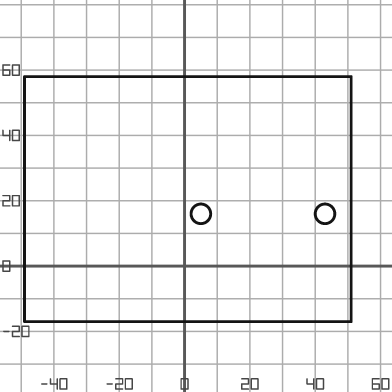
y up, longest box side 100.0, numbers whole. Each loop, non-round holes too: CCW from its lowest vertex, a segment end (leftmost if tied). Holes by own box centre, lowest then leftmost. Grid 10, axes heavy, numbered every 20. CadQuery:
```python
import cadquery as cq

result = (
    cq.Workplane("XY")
    .moveTo(-49.0, -17.0)
    .lineTo(51.0, -17.0)
    .lineTo(51.0, 58.0)
    .lineTo(-49.0, 58.0)
    .close()
    .moveTo(5.0, 16.0)
    .circle(3.0)
    .moveTo(43.0, 16.0)
    .circle(3.0)
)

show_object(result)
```